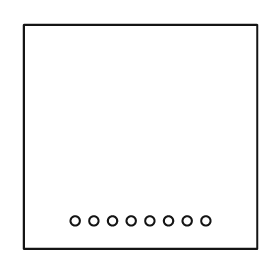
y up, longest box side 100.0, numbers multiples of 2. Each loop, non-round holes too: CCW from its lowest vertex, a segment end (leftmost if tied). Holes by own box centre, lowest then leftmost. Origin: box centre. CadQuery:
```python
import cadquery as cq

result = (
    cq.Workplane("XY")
    .moveTo(-50.0, -48.0)
    .lineTo(50.0, -48.0)
    .lineTo(50.0, 48.0)
    .lineTo(-50.0, 48.0)
    .close()
    .moveTo(-28.0, -36.0)
    .circle(2.0)
    .moveTo(-20.0, -36.0)
    .circle(2.0)
    .moveTo(-12.0, -36.0)
    .circle(2.0)
    .moveTo(-4.0, -36.0)
    .circle(2.0)
    .moveTo(4.0, -36.0)
    .circle(2.0)
    .moveTo(12.0, -36.0)
    .circle(2.0)
    .moveTo(20.0, -36.0)
    .circle(2.0)
    .moveTo(28.0, -36.0)
    .circle(2.0)
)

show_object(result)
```